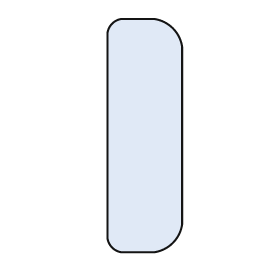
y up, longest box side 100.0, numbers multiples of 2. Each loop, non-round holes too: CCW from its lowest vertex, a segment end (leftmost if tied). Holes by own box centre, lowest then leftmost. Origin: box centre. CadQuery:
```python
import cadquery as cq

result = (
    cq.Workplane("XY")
    .moveTo(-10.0, -50.0)
    .lineTo(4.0, -50.0)
    .threePointArc((12.0, -46.0), (16.0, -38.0))
    .lineTo(16.0, 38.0)
    .threePointArc((12.0, 46.0), (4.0, 50.0))
    .lineTo(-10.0, 50.0)
    .threePointArc((-14.0, 48.0), (-16.0, 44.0))
    .lineTo(-16.0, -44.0)
    .threePointArc((-14.0, -48.0), (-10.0, -50.0))
    .close()
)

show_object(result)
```